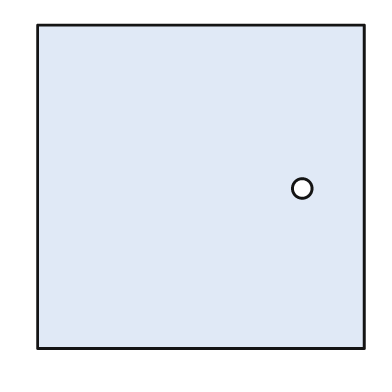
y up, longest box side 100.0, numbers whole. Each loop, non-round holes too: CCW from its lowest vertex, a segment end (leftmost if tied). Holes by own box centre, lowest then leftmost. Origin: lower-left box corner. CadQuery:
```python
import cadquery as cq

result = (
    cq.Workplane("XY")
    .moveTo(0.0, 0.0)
    .lineTo(100.0, 0.0)
    .lineTo(100.0, 99.0)
    .lineTo(0.0, 99.0)
    .close()
    .moveTo(81.0, 49.0)
    .circle(3.0)
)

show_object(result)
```